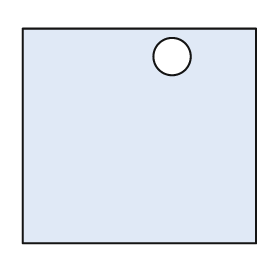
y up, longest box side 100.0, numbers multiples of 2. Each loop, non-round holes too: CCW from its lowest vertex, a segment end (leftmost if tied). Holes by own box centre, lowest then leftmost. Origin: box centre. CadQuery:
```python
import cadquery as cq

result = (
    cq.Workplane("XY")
    .moveTo(-50.0, -46.0)
    .lineTo(50.0, -46.0)
    .lineTo(50.0, 46.0)
    .lineTo(-50.0, 46.0)
    .close()
    .moveTo(14.0, 34.0)
    .circle(8.0)
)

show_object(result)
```